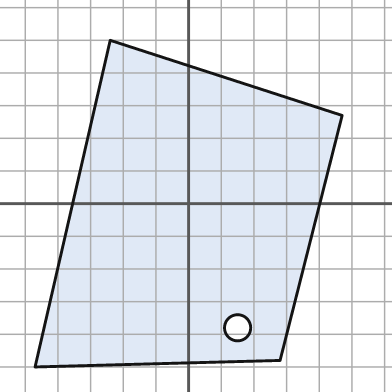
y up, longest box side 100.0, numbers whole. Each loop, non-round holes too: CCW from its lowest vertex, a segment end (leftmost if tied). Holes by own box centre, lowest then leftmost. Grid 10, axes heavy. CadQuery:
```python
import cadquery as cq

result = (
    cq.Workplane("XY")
    .moveTo(-47.0, -50.0)
    .lineTo(28.0, -48.0)
    .lineTo(47.0, 27.0)
    .lineTo(-24.0, 50.0)
    .close()
    .moveTo(15.0, -38.0)
    .circle(4.0)
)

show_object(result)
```